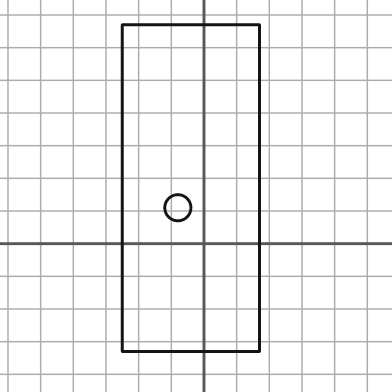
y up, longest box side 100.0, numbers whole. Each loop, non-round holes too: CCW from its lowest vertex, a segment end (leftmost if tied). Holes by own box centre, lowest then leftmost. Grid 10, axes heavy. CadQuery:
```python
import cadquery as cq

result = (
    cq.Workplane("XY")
    .moveTo(-25.0, -33.0)
    .lineTo(17.0, -33.0)
    .lineTo(17.0, 67.0)
    .lineTo(-25.0, 67.0)
    .close()
    .moveTo(-8.0, 11.0)
    .circle(4.0)
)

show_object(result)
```